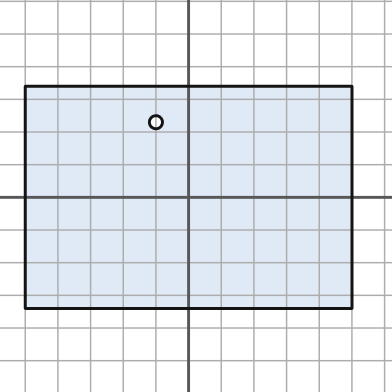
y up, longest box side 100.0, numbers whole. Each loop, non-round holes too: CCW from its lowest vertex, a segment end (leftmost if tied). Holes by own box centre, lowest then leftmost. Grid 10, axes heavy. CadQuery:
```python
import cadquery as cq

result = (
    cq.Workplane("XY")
    .moveTo(-50.0, -34.0)
    .lineTo(50.0, -34.0)
    .lineTo(50.0, 34.0)
    .lineTo(-50.0, 34.0)
    .close()
    .moveTo(-10.0, 23.0)
    .circle(2.0)
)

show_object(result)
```